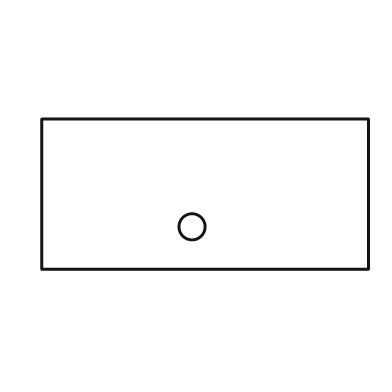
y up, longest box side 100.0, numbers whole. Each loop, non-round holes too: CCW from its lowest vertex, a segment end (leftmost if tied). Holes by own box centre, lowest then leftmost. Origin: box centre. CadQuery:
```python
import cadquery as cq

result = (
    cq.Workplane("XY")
    .moveTo(-50.0, -23.0)
    .lineTo(50.0, -23.0)
    .lineTo(50.0, 23.0)
    .lineTo(-50.0, 23.0)
    .close()
    .moveTo(-4.0, -10.0)
    .circle(4.0)
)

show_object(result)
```